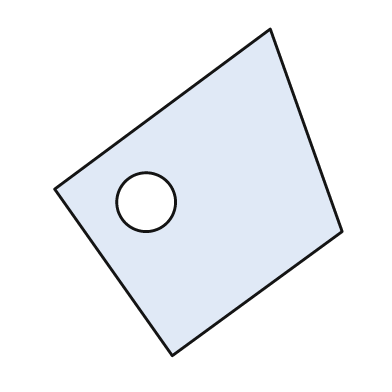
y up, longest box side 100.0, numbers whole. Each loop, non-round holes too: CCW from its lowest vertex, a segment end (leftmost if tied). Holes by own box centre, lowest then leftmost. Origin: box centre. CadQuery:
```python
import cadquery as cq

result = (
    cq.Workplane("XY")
    .moveTo(-8.0, -50.0)
    .lineTo(44.0, -12.0)
    .lineTo(22.0, 50.0)
    .lineTo(-44.0, 1.0)
    .close()
    .moveTo(-16.0, -3.0)
    .circle(9.0)
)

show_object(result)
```